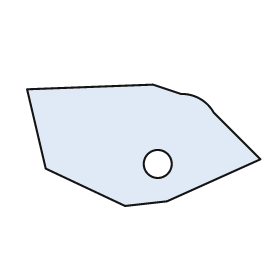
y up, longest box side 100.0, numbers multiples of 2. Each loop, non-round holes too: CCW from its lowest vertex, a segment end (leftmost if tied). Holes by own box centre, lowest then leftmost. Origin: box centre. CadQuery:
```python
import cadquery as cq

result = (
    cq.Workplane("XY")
    .moveTo(-8.0, -26.0)
    .lineTo(10.0, -24.0)
    .lineTo(50.0, -6.0)
    .lineTo(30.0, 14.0)
    .threePointArc((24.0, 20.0), (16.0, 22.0))
    .lineTo(4.0, 26.0)
    .lineTo(-50.0, 24.0)
    .lineTo(-42.0, -10.0)
    .close()
    .moveTo(6.0, -8.0)
    .circle(6.0)
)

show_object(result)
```